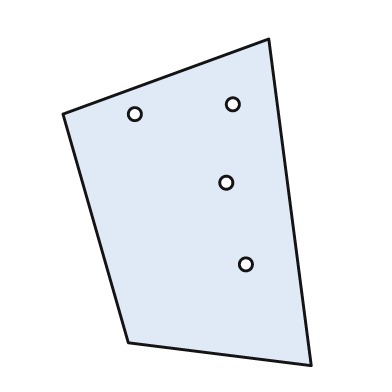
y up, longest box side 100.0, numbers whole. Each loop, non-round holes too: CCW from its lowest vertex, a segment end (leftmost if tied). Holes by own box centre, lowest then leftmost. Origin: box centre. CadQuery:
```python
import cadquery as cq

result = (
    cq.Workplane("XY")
    .moveTo(38.0, -50.0)
    .lineTo(25.0, 50.0)
    .lineTo(-38.0, 27.0)
    .lineTo(-18.0, -43.0)
    .close()
    .moveTo(18.0, -19.0)
    .circle(2.0)
    .moveTo(12.0, 6.0)
    .circle(2.0)
    .moveTo(-16.0, 27.0)
    .circle(2.0)
    .moveTo(14.0, 30.0)
    .circle(2.0)
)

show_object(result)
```